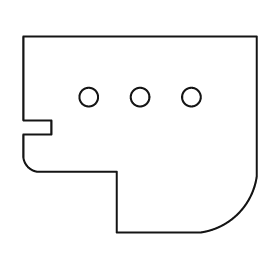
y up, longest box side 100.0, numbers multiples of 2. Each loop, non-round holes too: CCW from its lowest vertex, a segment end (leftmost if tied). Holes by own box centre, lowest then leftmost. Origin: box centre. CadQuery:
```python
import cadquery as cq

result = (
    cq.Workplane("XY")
    .moveTo(-10.0, -42.0)
    .lineTo(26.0, -42.0)
    .threePointArc((42.0, -34.0), (50.0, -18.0))
    .lineTo(50.0, 42.0)
    .lineTo(-50.0, 42.0)
    .lineTo(-50.0, 6.0)
    .lineTo(-38.0, 6.0)
    .lineTo(-38.0, 0.0)
    .lineTo(-50.0, 0.0)
    .lineTo(-50.0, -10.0)
    .threePointArc((-48.0, -14.0), (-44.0, -16.0))
    .lineTo(-10.0, -16.0)
    .close()
    .moveTo(-22.0, 16.0)
    .circle(4.0)
    .moveTo(0.0, 16.0)
    .circle(4.0)
    .moveTo(22.0, 16.0)
    .circle(4.0)
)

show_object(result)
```